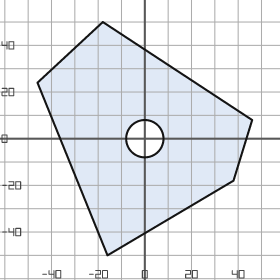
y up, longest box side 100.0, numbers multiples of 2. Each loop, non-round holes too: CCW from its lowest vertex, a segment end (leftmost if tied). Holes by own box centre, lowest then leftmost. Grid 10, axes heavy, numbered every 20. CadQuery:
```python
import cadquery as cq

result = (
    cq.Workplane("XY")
    .moveTo(-16.0, -50.0)
    .lineTo(38.0, -18.0)
    .lineTo(46.0, 8.0)
    .lineTo(-18.0, 50.0)
    .lineTo(-46.0, 24.0)
    .close()
    .moveTo(0.0, 0.0)
    .circle(8.0)
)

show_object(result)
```